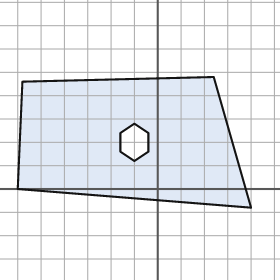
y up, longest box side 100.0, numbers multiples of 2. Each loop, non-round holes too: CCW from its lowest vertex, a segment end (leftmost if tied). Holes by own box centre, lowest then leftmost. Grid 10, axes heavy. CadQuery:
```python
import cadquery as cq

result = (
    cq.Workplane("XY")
    .moveTo(40.0, -8.0)
    .lineTo(24.0, 48.0)
    .lineTo(-58.0, 46.0)
    .lineTo(-60.0, 0.0)
    .close()
    .moveTo(-10.0, 12.0)
    .lineTo(-4.0, 16.0)
    .lineTo(-4.0, 24.0)
    .lineTo(-10.0, 28.0)
    .lineTo(-16.0, 24.0)
    .lineTo(-16.0, 16.0)
    .close()
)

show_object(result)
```